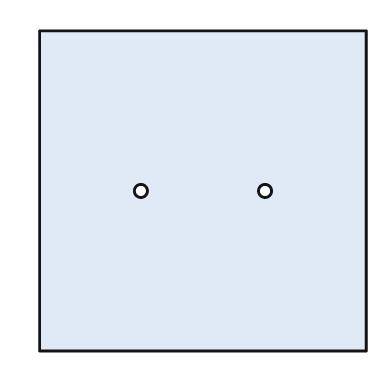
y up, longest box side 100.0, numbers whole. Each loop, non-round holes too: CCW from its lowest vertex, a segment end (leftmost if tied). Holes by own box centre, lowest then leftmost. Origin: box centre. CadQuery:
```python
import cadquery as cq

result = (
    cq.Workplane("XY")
    .moveTo(-50.0, -49.0)
    .lineTo(50.0, -49.0)
    .lineTo(50.0, 49.0)
    .lineTo(-50.0, 49.0)
    .close()
    .moveTo(-19.0, 0.0)
    .circle(2.0)
    .moveTo(19.0, 0.0)
    .circle(2.0)
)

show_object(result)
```